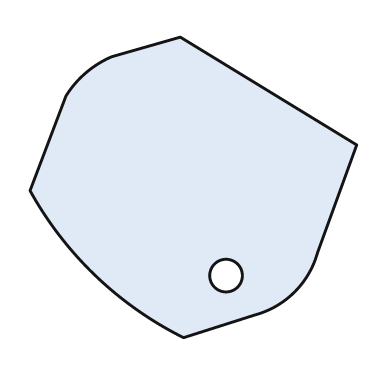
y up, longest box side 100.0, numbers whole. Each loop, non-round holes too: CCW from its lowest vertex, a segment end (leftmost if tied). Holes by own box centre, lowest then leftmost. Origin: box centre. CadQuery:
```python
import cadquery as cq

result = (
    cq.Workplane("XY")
    .moveTo(-3.0, -46.0)
    .lineTo(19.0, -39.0)
    .threePointArc((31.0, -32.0), (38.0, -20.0))
    .lineTo(50.0, 13.0)
    .lineTo(-4.0, 46.0)
    .lineTo(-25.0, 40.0)
    .threePointArc((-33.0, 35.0), (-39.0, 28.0))
    .lineTo(-50.0, -1.0)
    .threePointArc((-30.0, -27.0), (-3.0, -46.0))
    .close()
    .moveTo(10.0, -27.0)
    .circle(5.0)
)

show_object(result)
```